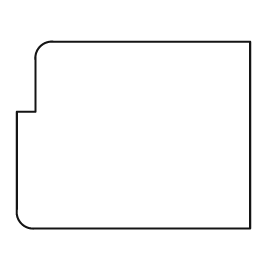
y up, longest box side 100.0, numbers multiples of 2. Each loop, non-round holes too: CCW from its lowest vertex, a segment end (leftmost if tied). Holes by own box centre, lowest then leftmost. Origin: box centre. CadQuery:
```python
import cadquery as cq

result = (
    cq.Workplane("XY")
    .moveTo(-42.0, -40.0)
    .lineTo(50.0, -40.0)
    .lineTo(50.0, 40.0)
    .lineTo(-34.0, 40.0)
    .threePointArc((-40.0, 38.0), (-42.0, 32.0))
    .lineTo(-42.0, 10.0)
    .lineTo(-50.0, 10.0)
    .lineTo(-50.0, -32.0)
    .threePointArc((-48.0, -38.0), (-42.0, -40.0))
    .close()
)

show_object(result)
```